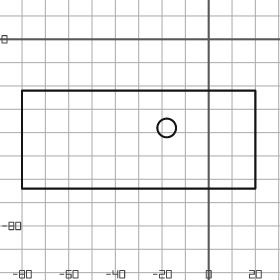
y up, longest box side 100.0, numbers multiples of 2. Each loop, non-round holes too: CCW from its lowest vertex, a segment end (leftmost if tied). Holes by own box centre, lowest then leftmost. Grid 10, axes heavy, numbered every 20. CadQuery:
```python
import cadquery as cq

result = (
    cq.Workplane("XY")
    .moveTo(-80.0, -64.0)
    .lineTo(20.0, -64.0)
    .lineTo(20.0, -22.0)
    .lineTo(-80.0, -22.0)
    .close()
    .moveTo(-18.0, -38.0)
    .circle(4.0)
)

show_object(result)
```